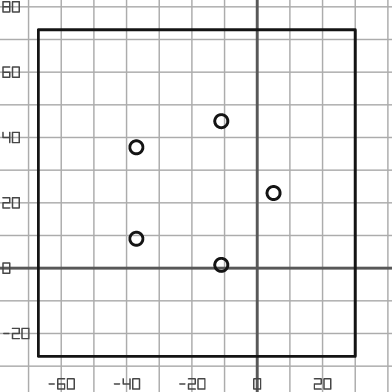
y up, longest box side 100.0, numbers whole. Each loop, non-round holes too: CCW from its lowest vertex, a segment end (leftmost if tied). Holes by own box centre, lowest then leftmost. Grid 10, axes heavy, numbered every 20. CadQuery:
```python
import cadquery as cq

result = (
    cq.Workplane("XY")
    .moveTo(-67.0, -27.0)
    .lineTo(30.0, -27.0)
    .lineTo(30.0, 73.0)
    .lineTo(-67.0, 73.0)
    .close()
    .moveTo(-11.0, 1.0)
    .circle(2.0)
    .moveTo(-37.0, 9.0)
    .circle(2.0)
    .moveTo(5.0, 23.0)
    .circle(2.0)
    .moveTo(-37.0, 37.0)
    .circle(2.0)
    .moveTo(-11.0, 45.0)
    .circle(2.0)
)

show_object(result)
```